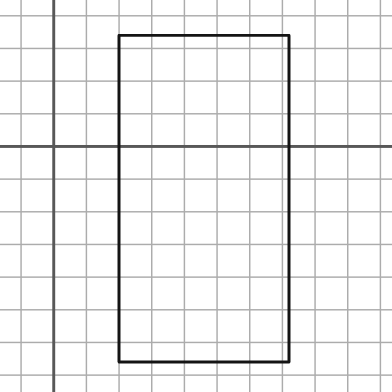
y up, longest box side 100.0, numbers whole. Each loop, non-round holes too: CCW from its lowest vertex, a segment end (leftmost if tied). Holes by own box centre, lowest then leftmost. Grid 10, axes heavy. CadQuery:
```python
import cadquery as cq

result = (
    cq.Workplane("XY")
    .moveTo(20.0, -66.0)
    .lineTo(72.0, -66.0)
    .lineTo(72.0, 34.0)
    .lineTo(20.0, 34.0)
    .close()
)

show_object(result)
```